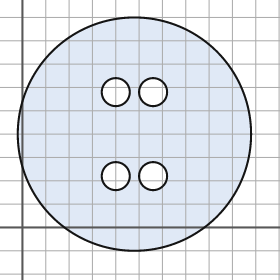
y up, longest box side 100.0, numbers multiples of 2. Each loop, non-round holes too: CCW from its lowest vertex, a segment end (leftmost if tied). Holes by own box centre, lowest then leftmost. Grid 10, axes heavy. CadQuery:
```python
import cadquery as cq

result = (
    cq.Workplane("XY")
    .moveTo(48.0, 40.0)
    .circle(50.0)
    .moveTo(40.0, 22.0)
    .circle(6.0)
    .moveTo(56.0, 22.0)
    .circle(6.0)
    .moveTo(40.0, 58.0)
    .circle(6.0)
    .moveTo(56.0, 58.0)
    .circle(6.0)
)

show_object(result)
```